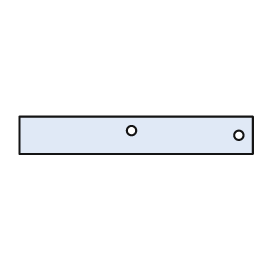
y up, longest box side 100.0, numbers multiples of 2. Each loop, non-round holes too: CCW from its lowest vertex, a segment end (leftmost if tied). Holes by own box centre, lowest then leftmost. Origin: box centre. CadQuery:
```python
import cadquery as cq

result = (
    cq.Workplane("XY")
    .moveTo(-50.0, -8.0)
    .lineTo(50.0, -8.0)
    .lineTo(50.0, 8.0)
    .lineTo(-50.0, 8.0)
    .close()
    .moveTo(44.0, 0.0)
    .circle(2.0)
    .moveTo(-2.0, 2.0)
    .circle(2.0)
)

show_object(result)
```